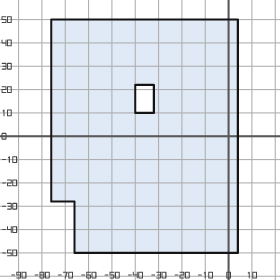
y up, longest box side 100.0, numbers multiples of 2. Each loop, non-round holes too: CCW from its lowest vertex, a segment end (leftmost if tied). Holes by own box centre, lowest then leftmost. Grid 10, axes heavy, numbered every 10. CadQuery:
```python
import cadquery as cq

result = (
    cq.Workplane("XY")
    .moveTo(-66.0, -50.0)
    .lineTo(4.0, -50.0)
    .lineTo(4.0, 50.0)
    .lineTo(-76.0, 50.0)
    .lineTo(-76.0, -28.0)
    .lineTo(-66.0, -28.0)
    .close()
    .moveTo(-40.0, 10.0)
    .lineTo(-32.0, 10.0)
    .lineTo(-32.0, 22.0)
    .lineTo(-40.0, 22.0)
    .close()
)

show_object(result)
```